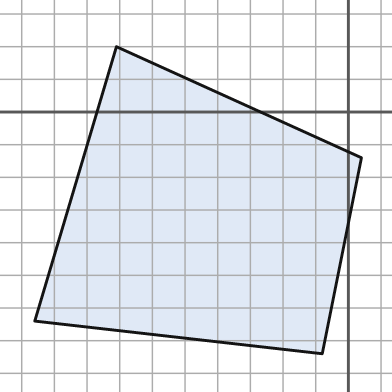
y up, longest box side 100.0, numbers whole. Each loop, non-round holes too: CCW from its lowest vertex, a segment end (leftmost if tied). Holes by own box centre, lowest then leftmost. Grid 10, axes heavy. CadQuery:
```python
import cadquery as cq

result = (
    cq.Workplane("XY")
    .moveTo(-8.0, -74.0)
    .lineTo(4.0, -14.0)
    .lineTo(-71.0, 20.0)
    .lineTo(-96.0, -64.0)
    .close()
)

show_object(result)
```